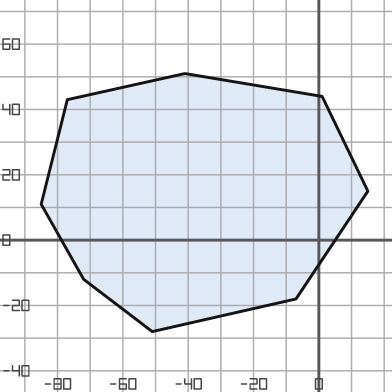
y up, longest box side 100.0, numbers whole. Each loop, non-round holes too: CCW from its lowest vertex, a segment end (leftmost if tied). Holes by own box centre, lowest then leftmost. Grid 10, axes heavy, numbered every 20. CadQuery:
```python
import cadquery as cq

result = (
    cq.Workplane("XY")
    .moveTo(-51.0, -28.0)
    .lineTo(-7.0, -18.0)
    .lineTo(15.0, 15.0)
    .lineTo(1.0, 44.0)
    .lineTo(-41.0, 51.0)
    .lineTo(-77.0, 43.0)
    .lineTo(-85.0, 11.0)
    .lineTo(-72.0, -12.0)
    .close()
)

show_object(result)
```